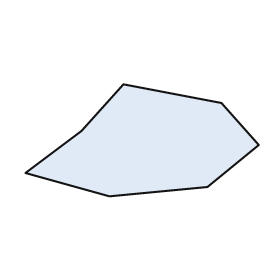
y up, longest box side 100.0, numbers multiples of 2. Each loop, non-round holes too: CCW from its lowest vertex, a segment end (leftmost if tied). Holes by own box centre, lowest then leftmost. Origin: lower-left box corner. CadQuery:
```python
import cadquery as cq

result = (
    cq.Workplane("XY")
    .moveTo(36.0, 0.0)
    .lineTo(78.0, 4.0)
    .lineTo(100.0, 22.0)
    .lineTo(84.0, 40.0)
    .lineTo(42.0, 48.0)
    .lineTo(24.0, 28.0)
    .lineTo(0.0, 10.0)
    .close()
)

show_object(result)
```